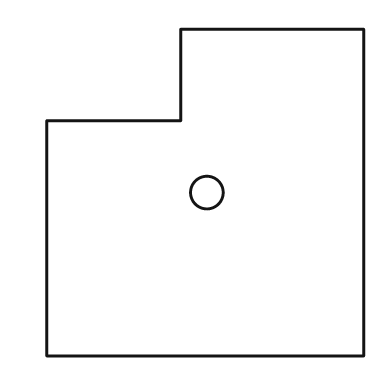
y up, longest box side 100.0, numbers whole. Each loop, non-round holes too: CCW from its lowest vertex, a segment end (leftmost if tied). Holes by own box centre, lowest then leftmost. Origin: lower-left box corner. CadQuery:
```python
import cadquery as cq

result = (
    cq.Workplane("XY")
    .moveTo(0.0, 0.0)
    .lineTo(97.0, 0.0)
    .lineTo(97.0, 100.0)
    .lineTo(41.0, 100.0)
    .lineTo(41.0, 72.0)
    .lineTo(0.0, 72.0)
    .close()
    .moveTo(49.0, 50.0)
    .circle(5.0)
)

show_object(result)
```